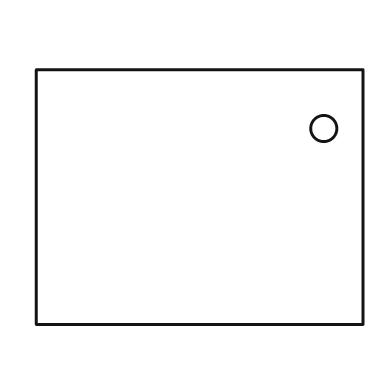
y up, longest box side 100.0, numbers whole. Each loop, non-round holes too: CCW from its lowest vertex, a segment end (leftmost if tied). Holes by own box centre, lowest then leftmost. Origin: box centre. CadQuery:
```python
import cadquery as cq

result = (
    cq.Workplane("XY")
    .moveTo(-50.0, -39.0)
    .lineTo(50.0, -39.0)
    .lineTo(50.0, 39.0)
    .lineTo(-50.0, 39.0)
    .close()
    .moveTo(38.0, 21.0)
    .circle(4.0)
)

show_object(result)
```